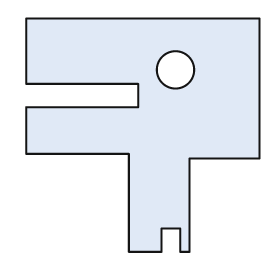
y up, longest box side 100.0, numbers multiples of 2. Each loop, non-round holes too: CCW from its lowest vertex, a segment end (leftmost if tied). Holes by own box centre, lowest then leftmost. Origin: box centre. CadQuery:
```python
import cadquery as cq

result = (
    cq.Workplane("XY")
    .moveTo(-6.0, -50.0)
    .lineTo(8.0, -50.0)
    .lineTo(8.0, -40.0)
    .lineTo(16.0, -40.0)
    .lineTo(16.0, -50.0)
    .lineTo(20.0, -50.0)
    .lineTo(20.0, -10.0)
    .lineTo(50.0, -10.0)
    .lineTo(50.0, 50.0)
    .lineTo(-50.0, 50.0)
    .lineTo(-50.0, 22.0)
    .lineTo(-2.0, 22.0)
    .lineTo(-2.0, 12.0)
    .lineTo(-50.0, 12.0)
    .lineTo(-50.0, -8.0)
    .lineTo(-6.0, -8.0)
    .close()
    .moveTo(14.0, 28.0)
    .circle(8.0)
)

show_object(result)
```